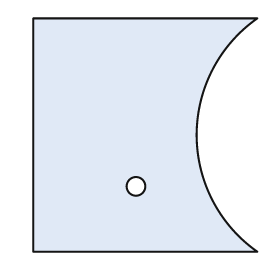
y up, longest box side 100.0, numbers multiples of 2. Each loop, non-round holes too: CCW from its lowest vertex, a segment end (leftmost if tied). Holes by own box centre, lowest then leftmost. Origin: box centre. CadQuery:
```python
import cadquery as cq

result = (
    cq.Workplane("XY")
    .moveTo(-48.0, -50.0)
    .lineTo(48.0, -50.0)
    .threePointArc((22.0, 0.0), (48.0, 50.0))
    .lineTo(-48.0, 50.0)
    .close()
    .moveTo(-4.0, -22.0)
    .circle(4.0)
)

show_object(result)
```